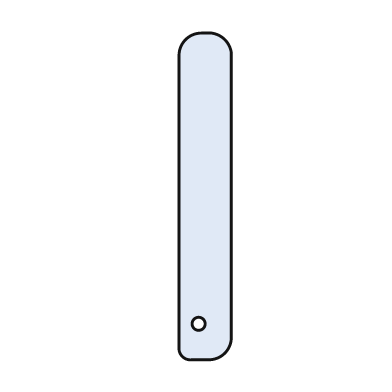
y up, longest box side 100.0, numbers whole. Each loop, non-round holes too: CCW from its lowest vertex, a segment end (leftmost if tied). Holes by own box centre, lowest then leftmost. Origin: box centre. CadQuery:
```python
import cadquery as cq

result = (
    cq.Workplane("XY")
    .moveTo(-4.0, -50.0)
    .lineTo(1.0, -50.0)
    .threePointArc((6.0, -48.0), (8.0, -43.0))
    .lineTo(8.0, 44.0)
    .threePointArc((6.0, 48.0), (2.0, 50.0))
    .lineTo(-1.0, 50.0)
    .threePointArc((-6.0, 48.0), (-8.0, 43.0))
    .lineTo(-8.0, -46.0)
    .threePointArc((-7.0, -49.0), (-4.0, -50.0))
    .close()
    .moveTo(-2.0, -39.0)
    .circle(2.0)
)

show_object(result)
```